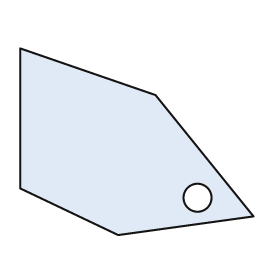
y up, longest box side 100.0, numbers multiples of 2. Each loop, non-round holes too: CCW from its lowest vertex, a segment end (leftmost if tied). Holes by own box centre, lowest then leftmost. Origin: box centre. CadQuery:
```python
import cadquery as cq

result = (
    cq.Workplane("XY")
    .moveTo(-8.0, -40.0)
    .lineTo(50.0, -32.0)
    .lineTo(8.0, 20.0)
    .lineTo(-50.0, 40.0)
    .lineTo(-50.0, -20.0)
    .close()
    .moveTo(26.0, -24.0)
    .circle(6.0)
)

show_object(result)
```